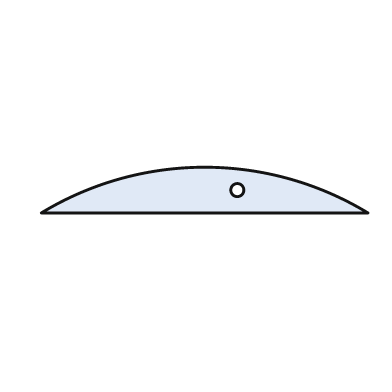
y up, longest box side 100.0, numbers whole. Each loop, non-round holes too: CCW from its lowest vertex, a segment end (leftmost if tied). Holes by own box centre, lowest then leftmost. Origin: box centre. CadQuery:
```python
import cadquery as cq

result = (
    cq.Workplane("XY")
    .moveTo(-50.0, -7.0)
    .lineTo(50.0, -7.0)
    .threePointArc((0.0, 7.0), (-50.0, -7.0))
    .close()
    .moveTo(10.0, 0.0)
    .circle(2.0)
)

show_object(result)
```